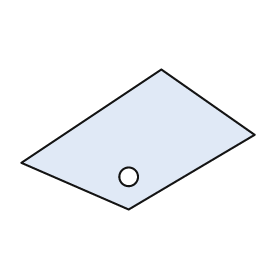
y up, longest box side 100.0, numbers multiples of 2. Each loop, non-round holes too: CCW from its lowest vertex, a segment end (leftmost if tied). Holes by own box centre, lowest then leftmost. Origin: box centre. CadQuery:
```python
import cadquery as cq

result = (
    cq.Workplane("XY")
    .moveTo(-4.0, -30.0)
    .lineTo(50.0, 2.0)
    .lineTo(10.0, 30.0)
    .lineTo(-50.0, -10.0)
    .close()
    .moveTo(-4.0, -16.0)
    .circle(4.0)
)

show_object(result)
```